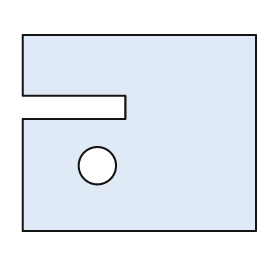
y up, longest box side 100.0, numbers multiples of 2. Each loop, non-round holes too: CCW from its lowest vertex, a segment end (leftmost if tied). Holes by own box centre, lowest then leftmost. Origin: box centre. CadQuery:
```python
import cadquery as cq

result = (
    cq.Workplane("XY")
    .moveTo(-50.0, -42.0)
    .lineTo(50.0, -42.0)
    .lineTo(50.0, 42.0)
    .lineTo(-50.0, 42.0)
    .lineTo(-50.0, 16.0)
    .lineTo(-6.0, 16.0)
    .lineTo(-6.0, 6.0)
    .lineTo(-50.0, 6.0)
    .close()
    .moveTo(-18.0, -14.0)
    .circle(8.0)
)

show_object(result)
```